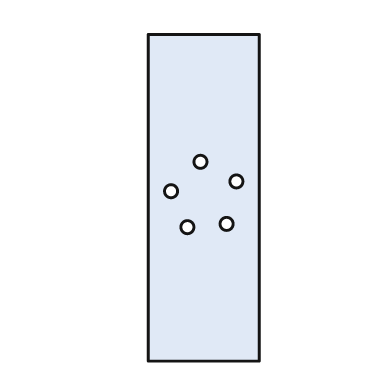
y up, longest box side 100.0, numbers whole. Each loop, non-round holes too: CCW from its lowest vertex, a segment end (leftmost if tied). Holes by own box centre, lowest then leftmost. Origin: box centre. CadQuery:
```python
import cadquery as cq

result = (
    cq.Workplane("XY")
    .moveTo(-17.0, -50.0)
    .lineTo(17.0, -50.0)
    .lineTo(17.0, 50.0)
    .lineTo(-17.0, 50.0)
    .close()
    .moveTo(-5.0, -9.0)
    .circle(2.0)
    .moveTo(7.0, -8.0)
    .circle(2.0)
    .moveTo(-10.0, 2.0)
    .circle(2.0)
    .moveTo(10.0, 5.0)
    .circle(2.0)
    .moveTo(-1.0, 11.0)
    .circle(2.0)
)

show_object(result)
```